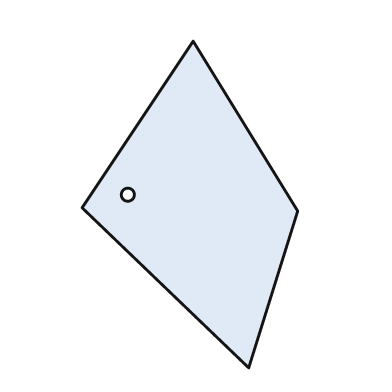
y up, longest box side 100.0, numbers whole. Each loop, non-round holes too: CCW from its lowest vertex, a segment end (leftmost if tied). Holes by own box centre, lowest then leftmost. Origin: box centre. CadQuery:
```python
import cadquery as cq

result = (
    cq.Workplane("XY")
    .moveTo(18.0, -50.0)
    .lineTo(33.0, -2.0)
    .lineTo(1.0, 50.0)
    .lineTo(-33.0, -1.0)
    .close()
    .moveTo(-19.0, 3.0)
    .circle(2.0)
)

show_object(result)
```